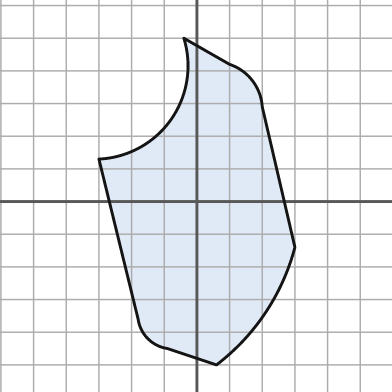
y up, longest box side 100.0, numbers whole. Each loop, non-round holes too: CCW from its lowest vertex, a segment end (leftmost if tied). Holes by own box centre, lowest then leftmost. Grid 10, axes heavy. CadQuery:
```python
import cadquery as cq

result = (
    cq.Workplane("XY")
    .moveTo(6.0, -50.0)
    .threePointArc((21.0, -34.0), (30.0, -14.0))
    .lineTo(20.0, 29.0)
    .threePointArc((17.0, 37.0), (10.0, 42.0))
    .lineTo(-4.0, 50.0)
    .threePointArc((-8.0, 25.0), (-30.0, 13.0))
    .lineTo(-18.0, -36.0)
    .threePointArc((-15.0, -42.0), (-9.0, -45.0))
    .close()
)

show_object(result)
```